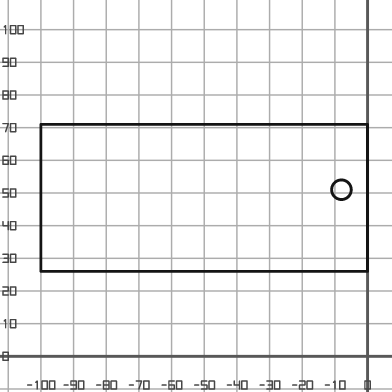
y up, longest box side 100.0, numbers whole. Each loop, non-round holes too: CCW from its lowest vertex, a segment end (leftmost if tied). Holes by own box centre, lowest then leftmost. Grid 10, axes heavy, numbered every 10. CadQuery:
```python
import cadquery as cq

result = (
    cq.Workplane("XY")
    .moveTo(-100.0, 26.0)
    .lineTo(0.0, 26.0)
    .lineTo(0.0, 71.0)
    .lineTo(-100.0, 71.0)
    .close()
    .moveTo(-8.0, 51.0)
    .circle(3.0)
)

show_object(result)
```